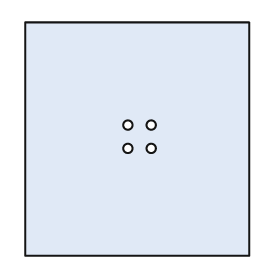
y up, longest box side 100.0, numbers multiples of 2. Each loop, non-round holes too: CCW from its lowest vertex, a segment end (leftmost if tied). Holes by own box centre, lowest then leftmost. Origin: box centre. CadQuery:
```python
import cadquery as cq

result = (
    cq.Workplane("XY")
    .moveTo(-48.0, -50.0)
    .lineTo(48.0, -50.0)
    .lineTo(48.0, 50.0)
    .lineTo(-48.0, 50.0)
    .close()
    .moveTo(-4.0, -4.0)
    .circle(2.0)
    .moveTo(6.0, -4.0)
    .circle(2.0)
    .moveTo(-4.0, 6.0)
    .circle(2.0)
    .moveTo(6.0, 6.0)
    .circle(2.0)
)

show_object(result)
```